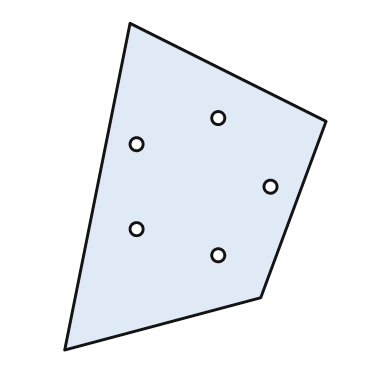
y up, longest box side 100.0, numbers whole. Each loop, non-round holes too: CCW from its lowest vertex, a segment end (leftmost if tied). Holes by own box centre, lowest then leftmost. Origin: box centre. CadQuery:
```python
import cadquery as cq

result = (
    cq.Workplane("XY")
    .moveTo(-40.0, -50.0)
    .lineTo(20.0, -34.0)
    .lineTo(40.0, 20.0)
    .lineTo(-20.0, 50.0)
    .close()
    .moveTo(7.0, -21.0)
    .circle(2.0)
    .moveTo(-18.0, -13.0)
    .circle(2.0)
    .moveTo(23.0, 0.0)
    .circle(2.0)
    .moveTo(-18.0, 13.0)
    .circle(2.0)
    .moveTo(7.0, 21.0)
    .circle(2.0)
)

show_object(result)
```